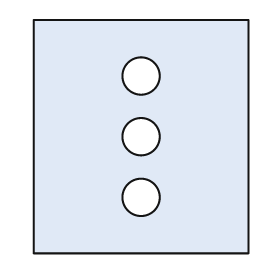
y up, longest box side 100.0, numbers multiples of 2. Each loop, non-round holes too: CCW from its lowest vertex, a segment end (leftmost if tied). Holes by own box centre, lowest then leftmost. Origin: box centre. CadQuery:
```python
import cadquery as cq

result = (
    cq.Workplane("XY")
    .moveTo(-46.0, -50.0)
    .lineTo(46.0, -50.0)
    .lineTo(46.0, 50.0)
    .lineTo(-46.0, 50.0)
    .close()
    .moveTo(0.0, -26.0)
    .circle(8.0)
    .moveTo(0.0, 0.0)
    .circle(8.0)
    .moveTo(0.0, 26.0)
    .circle(8.0)
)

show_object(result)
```